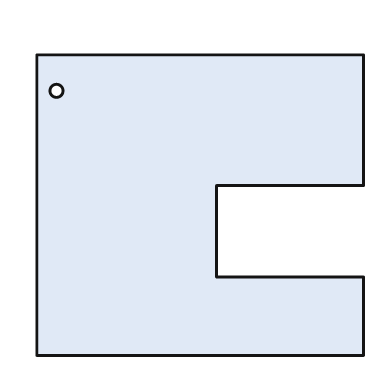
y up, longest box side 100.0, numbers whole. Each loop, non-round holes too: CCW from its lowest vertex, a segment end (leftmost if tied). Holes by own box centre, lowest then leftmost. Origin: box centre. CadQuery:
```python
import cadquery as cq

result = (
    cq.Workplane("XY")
    .moveTo(-50.0, -46.0)
    .lineTo(50.0, -46.0)
    .lineTo(50.0, -22.0)
    .lineTo(5.0, -22.0)
    .lineTo(5.0, 6.0)
    .lineTo(50.0, 6.0)
    .lineTo(50.0, 46.0)
    .lineTo(-50.0, 46.0)
    .close()
    .moveTo(-44.0, 35.0)
    .circle(2.0)
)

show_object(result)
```